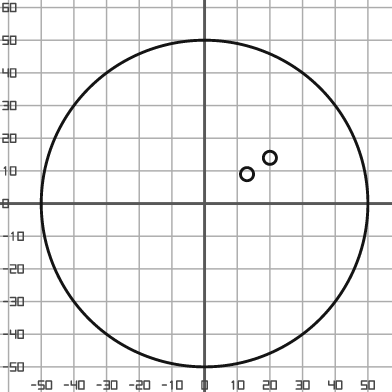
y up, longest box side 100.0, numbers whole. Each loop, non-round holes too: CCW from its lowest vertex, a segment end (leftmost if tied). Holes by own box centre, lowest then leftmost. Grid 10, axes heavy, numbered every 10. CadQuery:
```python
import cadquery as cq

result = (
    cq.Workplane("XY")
    .moveTo(0.0, 0.0)
    .circle(50.0)
    .moveTo(13.0, 9.0)
    .circle(2.0)
    .moveTo(20.0, 14.0)
    .circle(2.0)
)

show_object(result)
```